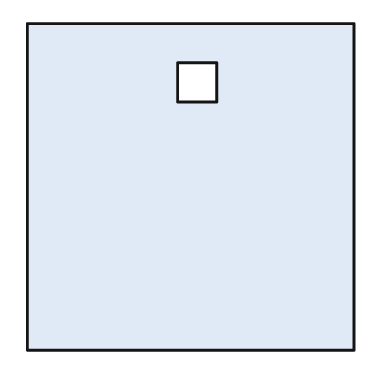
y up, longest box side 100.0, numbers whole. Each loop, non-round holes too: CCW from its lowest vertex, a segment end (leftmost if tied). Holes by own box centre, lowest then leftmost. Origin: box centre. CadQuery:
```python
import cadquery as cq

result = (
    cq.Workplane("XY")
    .moveTo(-50.0, -50.0)
    .lineTo(50.0, -50.0)
    .lineTo(50.0, 50.0)
    .lineTo(-50.0, 50.0)
    .close()
    .moveTo(-4.0, 26.0)
    .lineTo(8.0, 26.0)
    .lineTo(8.0, 38.0)
    .lineTo(-4.0, 38.0)
    .close()
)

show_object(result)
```